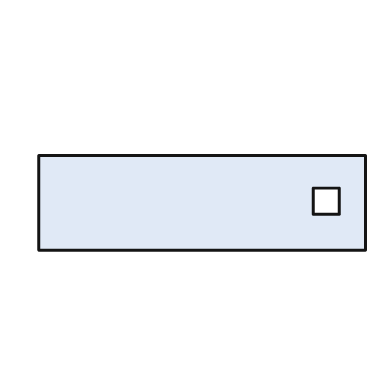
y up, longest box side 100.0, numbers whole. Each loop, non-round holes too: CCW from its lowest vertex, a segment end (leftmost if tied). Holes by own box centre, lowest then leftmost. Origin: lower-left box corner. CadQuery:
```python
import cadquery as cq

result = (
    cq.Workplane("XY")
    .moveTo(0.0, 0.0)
    .lineTo(100.0, 0.0)
    .lineTo(100.0, 29.0)
    .lineTo(0.0, 29.0)
    .close()
    .moveTo(84.0, 11.0)
    .lineTo(92.0, 11.0)
    .lineTo(92.0, 19.0)
    .lineTo(84.0, 19.0)
    .close()
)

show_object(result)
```